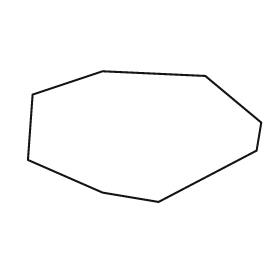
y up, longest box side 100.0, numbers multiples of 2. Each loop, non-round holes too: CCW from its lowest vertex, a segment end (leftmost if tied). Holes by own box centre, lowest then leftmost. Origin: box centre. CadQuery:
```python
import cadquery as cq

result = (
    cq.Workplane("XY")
    .moveTo(6.0, -28.0)
    .lineTo(48.0, -6.0)
    .lineTo(50.0, 6.0)
    .lineTo(26.0, 26.0)
    .lineTo(-18.0, 28.0)
    .lineTo(-48.0, 18.0)
    .lineTo(-50.0, -10.0)
    .lineTo(-18.0, -24.0)
    .close()
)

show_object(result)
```